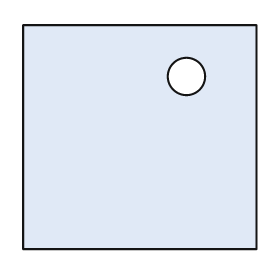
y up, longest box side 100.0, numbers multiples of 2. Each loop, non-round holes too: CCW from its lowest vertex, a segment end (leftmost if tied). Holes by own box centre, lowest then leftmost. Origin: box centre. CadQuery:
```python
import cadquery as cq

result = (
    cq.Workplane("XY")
    .moveTo(-50.0, -48.0)
    .lineTo(50.0, -48.0)
    .lineTo(50.0, 48.0)
    .lineTo(-50.0, 48.0)
    .close()
    .moveTo(20.0, 26.0)
    .circle(8.0)
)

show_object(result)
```